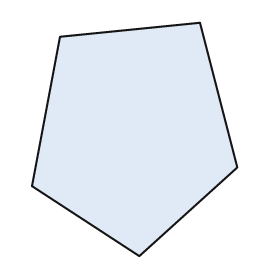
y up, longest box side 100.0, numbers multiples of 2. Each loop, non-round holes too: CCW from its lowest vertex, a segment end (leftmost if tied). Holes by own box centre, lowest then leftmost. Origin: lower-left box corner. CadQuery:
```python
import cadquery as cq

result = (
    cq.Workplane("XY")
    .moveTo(46.0, 0.0)
    .lineTo(88.0, 38.0)
    .lineTo(72.0, 100.0)
    .lineTo(12.0, 94.0)
    .lineTo(0.0, 30.0)
    .close()
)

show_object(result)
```